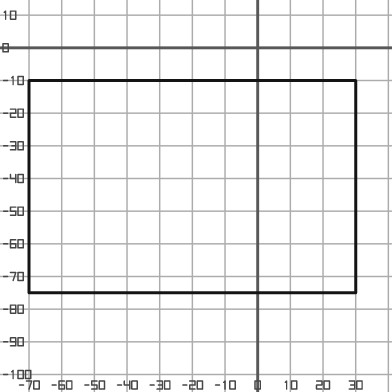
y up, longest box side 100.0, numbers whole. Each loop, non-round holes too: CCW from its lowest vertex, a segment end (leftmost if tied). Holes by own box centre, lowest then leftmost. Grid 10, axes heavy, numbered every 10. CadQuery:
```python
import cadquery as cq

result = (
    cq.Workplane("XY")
    .moveTo(-70.0, -75.0)
    .lineTo(30.0, -75.0)
    .lineTo(30.0, -10.0)
    .lineTo(-70.0, -10.0)
    .close()
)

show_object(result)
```